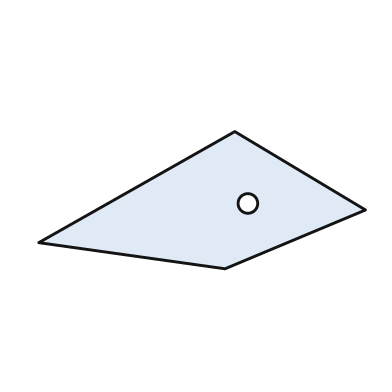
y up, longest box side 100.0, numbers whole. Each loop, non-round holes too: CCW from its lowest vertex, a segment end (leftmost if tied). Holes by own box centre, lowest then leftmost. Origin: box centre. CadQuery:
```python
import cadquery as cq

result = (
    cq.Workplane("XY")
    .moveTo(7.0, -21.0)
    .lineTo(50.0, -3.0)
    .lineTo(10.0, 21.0)
    .lineTo(-50.0, -13.0)
    .close()
    .moveTo(14.0, -1.0)
    .circle(3.0)
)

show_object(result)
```